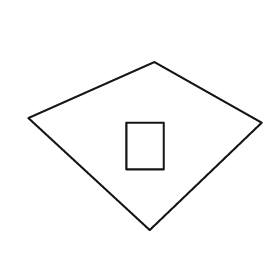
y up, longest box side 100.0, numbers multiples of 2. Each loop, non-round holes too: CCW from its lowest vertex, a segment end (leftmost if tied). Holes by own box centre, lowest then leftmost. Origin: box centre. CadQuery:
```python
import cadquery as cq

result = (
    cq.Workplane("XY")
    .moveTo(2.0, -36.0)
    .lineTo(50.0, 10.0)
    .lineTo(4.0, 36.0)
    .lineTo(-50.0, 12.0)
    .close()
    .moveTo(-8.0, -10.0)
    .lineTo(8.0, -10.0)
    .lineTo(8.0, 10.0)
    .lineTo(-8.0, 10.0)
    .close()
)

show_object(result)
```